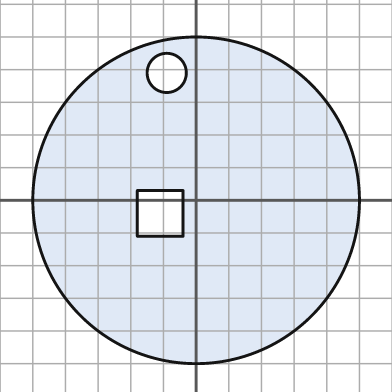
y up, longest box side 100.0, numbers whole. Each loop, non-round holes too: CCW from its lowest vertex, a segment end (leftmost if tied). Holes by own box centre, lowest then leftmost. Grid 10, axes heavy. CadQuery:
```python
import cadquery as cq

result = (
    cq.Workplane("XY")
    .moveTo(0.0, 0.0)
    .circle(50.0)
    .moveTo(-18.0, -11.0)
    .lineTo(-4.0, -11.0)
    .lineTo(-4.0, 3.0)
    .lineTo(-18.0, 3.0)
    .close()
    .moveTo(-9.0, 39.0)
    .circle(6.0)
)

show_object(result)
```